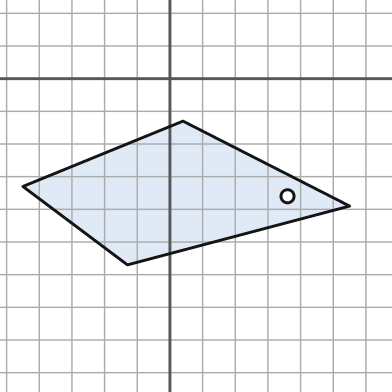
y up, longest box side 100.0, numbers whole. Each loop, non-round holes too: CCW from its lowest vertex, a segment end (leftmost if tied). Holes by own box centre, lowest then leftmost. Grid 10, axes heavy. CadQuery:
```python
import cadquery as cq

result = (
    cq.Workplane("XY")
    .moveTo(-13.0, -57.0)
    .lineTo(55.0, -39.0)
    .lineTo(4.0, -13.0)
    .lineTo(-45.0, -33.0)
    .close()
    .moveTo(36.0, -36.0)
    .circle(2.0)
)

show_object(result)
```